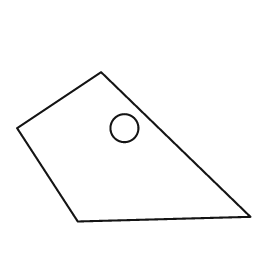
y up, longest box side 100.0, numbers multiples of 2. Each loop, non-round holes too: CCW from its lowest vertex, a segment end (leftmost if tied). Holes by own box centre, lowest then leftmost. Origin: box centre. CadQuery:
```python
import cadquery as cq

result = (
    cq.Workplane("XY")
    .moveTo(-24.0, -32.0)
    .lineTo(50.0, -30.0)
    .lineTo(-14.0, 32.0)
    .lineTo(-50.0, 8.0)
    .close()
    .moveTo(-4.0, 8.0)
    .circle(6.0)
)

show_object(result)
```